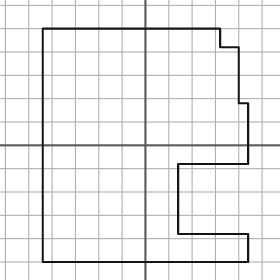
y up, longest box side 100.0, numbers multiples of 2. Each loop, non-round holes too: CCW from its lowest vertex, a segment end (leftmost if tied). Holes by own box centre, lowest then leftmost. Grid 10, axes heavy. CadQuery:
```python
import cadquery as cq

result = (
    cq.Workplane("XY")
    .moveTo(-44.0, -50.0)
    .lineTo(44.0, -50.0)
    .lineTo(44.0, -38.0)
    .lineTo(14.0, -38.0)
    .lineTo(14.0, -8.0)
    .lineTo(44.0, -8.0)
    .lineTo(44.0, 18.0)
    .lineTo(40.0, 18.0)
    .lineTo(40.0, 42.0)
    .lineTo(32.0, 42.0)
    .lineTo(32.0, 50.0)
    .lineTo(-44.0, 50.0)
    .close()
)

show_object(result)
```